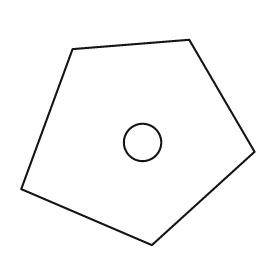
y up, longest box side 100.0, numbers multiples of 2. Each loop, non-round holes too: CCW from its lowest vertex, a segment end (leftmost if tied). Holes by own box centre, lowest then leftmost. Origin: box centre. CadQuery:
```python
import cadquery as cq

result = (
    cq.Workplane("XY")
    .moveTo(6.0, -44.0)
    .lineTo(50.0, -4.0)
    .lineTo(22.0, 44.0)
    .lineTo(-28.0, 40.0)
    .lineTo(-50.0, -20.0)
    .close()
    .moveTo(2.0, 0.0)
    .circle(8.0)
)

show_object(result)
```